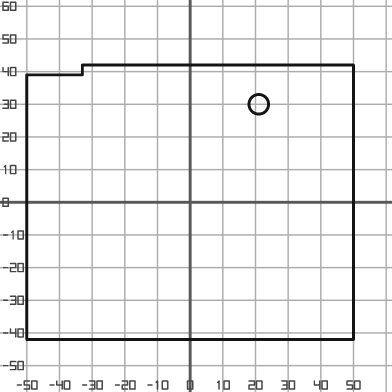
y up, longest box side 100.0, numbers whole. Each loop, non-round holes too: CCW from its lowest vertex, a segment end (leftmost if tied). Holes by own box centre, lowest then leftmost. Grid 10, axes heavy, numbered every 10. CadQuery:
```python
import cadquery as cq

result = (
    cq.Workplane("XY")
    .moveTo(-50.0, -42.0)
    .lineTo(50.0, -42.0)
    .lineTo(50.0, 42.0)
    .lineTo(-33.0, 42.0)
    .lineTo(-33.0, 39.0)
    .lineTo(-50.0, 39.0)
    .close()
    .moveTo(21.0, 30.0)
    .circle(3.0)
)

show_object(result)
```